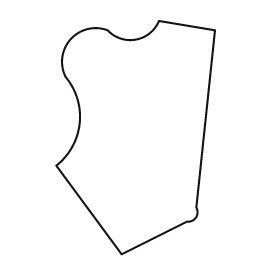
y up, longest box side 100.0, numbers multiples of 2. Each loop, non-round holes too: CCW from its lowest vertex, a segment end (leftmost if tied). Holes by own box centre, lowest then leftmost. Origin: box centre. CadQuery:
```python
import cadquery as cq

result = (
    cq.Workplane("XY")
    .moveTo(-6.0, -50.0)
    .lineTo(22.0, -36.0)
    .threePointArc((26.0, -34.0), (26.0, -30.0))
    .lineTo(34.0, 46.0)
    .lineTo(10.0, 50.0)
    .threePointArc((0.0, 42.0), (-12.0, 46.0))
    .threePointArc((-28.0, 42.0), (-30.0, 26.0))
    .threePointArc((-24.0, 6.0), (-34.0, -12.0))
    .close()
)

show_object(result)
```